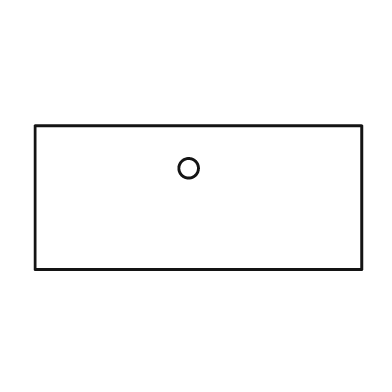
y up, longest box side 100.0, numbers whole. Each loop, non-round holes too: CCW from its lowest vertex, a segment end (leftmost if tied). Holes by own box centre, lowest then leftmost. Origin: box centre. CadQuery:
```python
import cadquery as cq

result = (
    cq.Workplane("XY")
    .moveTo(-50.0, -22.0)
    .lineTo(50.0, -22.0)
    .lineTo(50.0, 22.0)
    .lineTo(-50.0, 22.0)
    .close()
    .moveTo(-3.0, 9.0)
    .circle(3.0)
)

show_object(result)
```